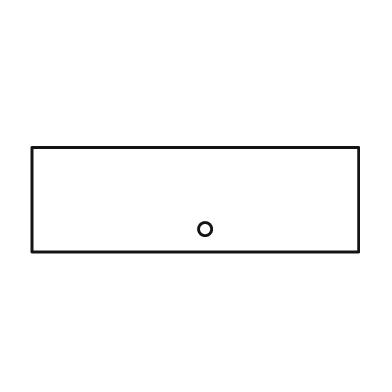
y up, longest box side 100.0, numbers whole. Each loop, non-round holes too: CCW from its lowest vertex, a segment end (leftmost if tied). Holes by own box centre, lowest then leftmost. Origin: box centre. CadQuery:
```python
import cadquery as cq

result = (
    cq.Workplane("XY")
    .moveTo(-50.0, -16.0)
    .lineTo(50.0, -16.0)
    .lineTo(50.0, 16.0)
    .lineTo(-50.0, 16.0)
    .close()
    .moveTo(3.0, -9.0)
    .circle(2.0)
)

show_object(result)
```